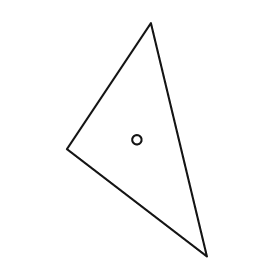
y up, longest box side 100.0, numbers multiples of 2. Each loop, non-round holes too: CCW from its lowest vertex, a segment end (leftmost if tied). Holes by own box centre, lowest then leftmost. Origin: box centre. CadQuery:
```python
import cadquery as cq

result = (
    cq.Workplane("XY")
    .moveTo(30.0, -50.0)
    .lineTo(6.0, 50.0)
    .lineTo(-30.0, -4.0)
    .close()
    .moveTo(0.0, 0.0)
    .circle(2.0)
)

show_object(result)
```